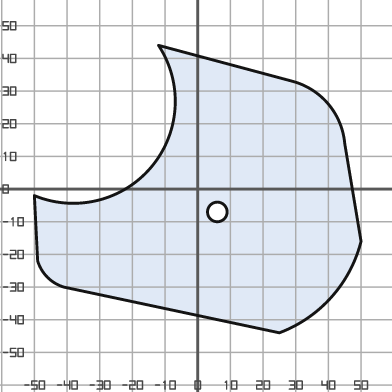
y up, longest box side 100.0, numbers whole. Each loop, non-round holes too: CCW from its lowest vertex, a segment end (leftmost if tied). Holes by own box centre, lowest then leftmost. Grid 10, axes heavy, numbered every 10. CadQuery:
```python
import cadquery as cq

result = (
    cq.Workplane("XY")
    .moveTo(25.0, -44.0)
    .threePointArc((41.0, -33.0), (50.0, -16.0))
    .lineTo(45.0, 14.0)
    .threePointArc((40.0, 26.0), (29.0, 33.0))
    .lineTo(-12.0, 44.0)
    .threePointArc((-14.0, 7.0), (-50.0, -2.0))
    .lineTo(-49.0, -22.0)
    .threePointArc((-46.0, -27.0), (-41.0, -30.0))
    .close()
    .moveTo(6.0, -7.0)
    .circle(3.0)
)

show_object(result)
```